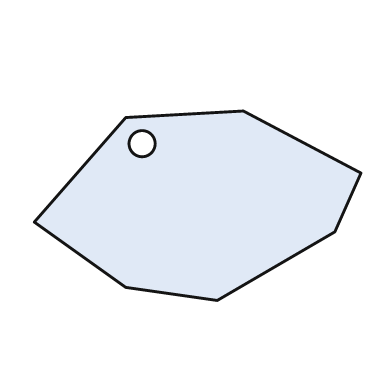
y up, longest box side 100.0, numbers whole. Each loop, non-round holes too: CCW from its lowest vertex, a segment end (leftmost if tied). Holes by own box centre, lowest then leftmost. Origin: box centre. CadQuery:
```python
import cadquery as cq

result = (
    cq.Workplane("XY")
    .moveTo(6.0, -29.0)
    .lineTo(42.0, -8.0)
    .lineTo(50.0, 10.0)
    .lineTo(14.0, 29.0)
    .lineTo(-22.0, 27.0)
    .lineTo(-50.0, -5.0)
    .lineTo(-22.0, -25.0)
    .close()
    .moveTo(-17.0, 19.0)
    .circle(4.0)
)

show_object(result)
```